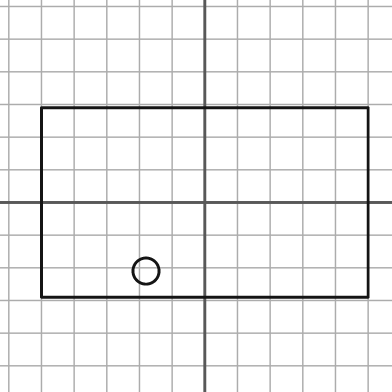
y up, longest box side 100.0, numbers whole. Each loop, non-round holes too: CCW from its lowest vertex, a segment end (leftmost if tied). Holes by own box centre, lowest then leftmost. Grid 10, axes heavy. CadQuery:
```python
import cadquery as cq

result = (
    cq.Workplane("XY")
    .moveTo(-50.0, -29.0)
    .lineTo(50.0, -29.0)
    .lineTo(50.0, 29.0)
    .lineTo(-50.0, 29.0)
    .close()
    .moveTo(-18.0, -21.0)
    .circle(4.0)
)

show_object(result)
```